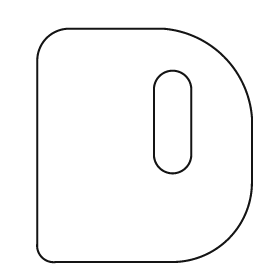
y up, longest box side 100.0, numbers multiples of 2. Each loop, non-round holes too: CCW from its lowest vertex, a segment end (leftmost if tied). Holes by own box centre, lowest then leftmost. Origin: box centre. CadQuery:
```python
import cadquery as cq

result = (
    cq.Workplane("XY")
    .moveTo(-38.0, -50.0)
    .lineTo(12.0, -50.0)
    .threePointArc((36.0, -40.0), (46.0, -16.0))
    .lineTo(46.0, 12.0)
    .threePointArc((34.0, 38.0), (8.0, 50.0))
    .lineTo(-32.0, 50.0)
    .threePointArc((-42.0, 46.0), (-46.0, 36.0))
    .lineTo(-46.0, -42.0)
    .threePointArc((-44.0, -48.0), (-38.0, -50.0))
    .close()
    .moveTo(4.0, -4.0)
    .threePointArc((12.0, -12.0), (20.0, -4.0))
    .lineTo(20.0, 24.0)
    .threePointArc((12.0, 32.0), (4.0, 24.0))
    .close()
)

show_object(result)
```